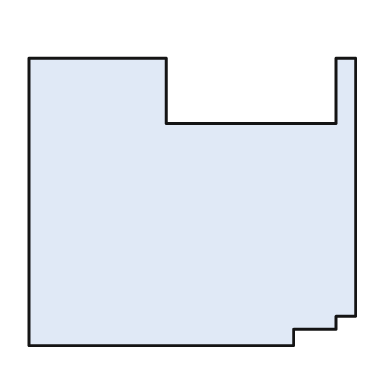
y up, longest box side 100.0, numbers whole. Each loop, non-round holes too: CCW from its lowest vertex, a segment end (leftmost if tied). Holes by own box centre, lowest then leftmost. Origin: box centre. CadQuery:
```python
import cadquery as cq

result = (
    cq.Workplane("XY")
    .moveTo(-50.0, -44.0)
    .lineTo(31.0, -44.0)
    .lineTo(31.0, -39.0)
    .lineTo(44.0, -39.0)
    .lineTo(44.0, -35.0)
    .lineTo(50.0, -35.0)
    .lineTo(50.0, 44.0)
    .lineTo(44.0, 44.0)
    .lineTo(44.0, 24.0)
    .lineTo(-8.0, 24.0)
    .lineTo(-8.0, 44.0)
    .lineTo(-50.0, 44.0)
    .close()
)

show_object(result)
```